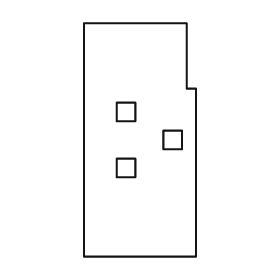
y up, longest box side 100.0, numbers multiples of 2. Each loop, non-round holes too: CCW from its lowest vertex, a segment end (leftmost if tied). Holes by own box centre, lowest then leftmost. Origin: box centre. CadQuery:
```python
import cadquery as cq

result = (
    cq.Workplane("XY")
    .moveTo(-24.0, -50.0)
    .lineTo(24.0, -50.0)
    .lineTo(24.0, 22.0)
    .lineTo(20.0, 22.0)
    .lineTo(20.0, 50.0)
    .lineTo(-24.0, 50.0)
    .close()
    .moveTo(-10.0, -16.0)
    .lineTo(-2.0, -16.0)
    .lineTo(-2.0, -8.0)
    .lineTo(-10.0, -8.0)
    .close()
    .moveTo(10.0, -4.0)
    .lineTo(18.0, -4.0)
    .lineTo(18.0, 4.0)
    .lineTo(10.0, 4.0)
    .close()
    .moveTo(-10.0, 8.0)
    .lineTo(-2.0, 8.0)
    .lineTo(-2.0, 16.0)
    .lineTo(-10.0, 16.0)
    .close()
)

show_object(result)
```